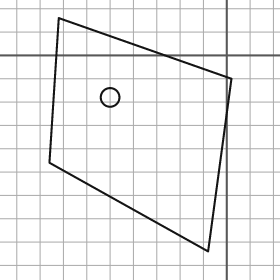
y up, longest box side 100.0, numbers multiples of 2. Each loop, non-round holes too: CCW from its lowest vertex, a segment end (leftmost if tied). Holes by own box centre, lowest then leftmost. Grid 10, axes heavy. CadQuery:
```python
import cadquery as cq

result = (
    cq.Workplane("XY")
    .moveTo(-8.0, -84.0)
    .lineTo(2.0, -10.0)
    .lineTo(-72.0, 16.0)
    .lineTo(-76.0, -46.0)
    .close()
    .moveTo(-50.0, -18.0)
    .circle(4.0)
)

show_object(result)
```